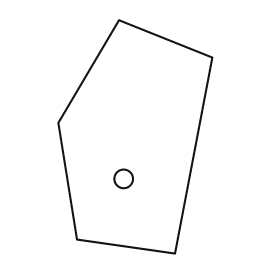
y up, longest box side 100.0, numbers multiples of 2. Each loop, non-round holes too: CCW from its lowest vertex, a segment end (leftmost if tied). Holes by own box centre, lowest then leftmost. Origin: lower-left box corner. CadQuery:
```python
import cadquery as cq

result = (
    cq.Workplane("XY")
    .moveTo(50.0, 0.0)
    .lineTo(66.0, 84.0)
    .lineTo(26.0, 100.0)
    .lineTo(0.0, 56.0)
    .lineTo(8.0, 6.0)
    .close()
    .moveTo(28.0, 32.0)
    .circle(4.0)
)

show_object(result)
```